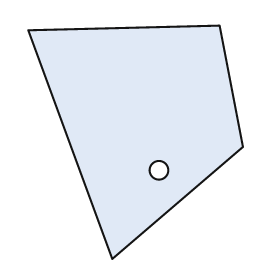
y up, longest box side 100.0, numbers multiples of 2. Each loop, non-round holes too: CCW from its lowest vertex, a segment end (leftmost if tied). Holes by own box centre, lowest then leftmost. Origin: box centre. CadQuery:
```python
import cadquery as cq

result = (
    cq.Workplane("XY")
    .moveTo(-10.0, -50.0)
    .lineTo(46.0, -2.0)
    .lineTo(36.0, 50.0)
    .lineTo(-46.0, 48.0)
    .close()
    .moveTo(10.0, -12.0)
    .circle(4.0)
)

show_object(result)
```